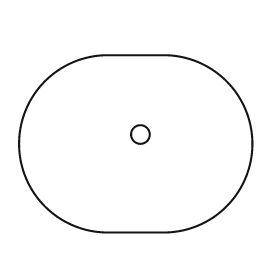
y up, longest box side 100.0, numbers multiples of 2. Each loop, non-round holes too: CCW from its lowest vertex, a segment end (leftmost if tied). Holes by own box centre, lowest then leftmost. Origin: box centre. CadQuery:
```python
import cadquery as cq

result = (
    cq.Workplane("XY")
    .moveTo(-12.0, -38.0)
    .lineTo(12.0, -38.0)
    .threePointArc((50.0, 0.0), (12.0, 38.0))
    .lineTo(-12.0, 38.0)
    .threePointArc((-50.0, 0.0), (-12.0, -38.0))
    .close()
    .moveTo(2.0, 4.0)
    .circle(4.0)
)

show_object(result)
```